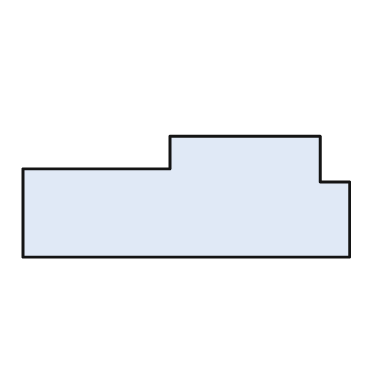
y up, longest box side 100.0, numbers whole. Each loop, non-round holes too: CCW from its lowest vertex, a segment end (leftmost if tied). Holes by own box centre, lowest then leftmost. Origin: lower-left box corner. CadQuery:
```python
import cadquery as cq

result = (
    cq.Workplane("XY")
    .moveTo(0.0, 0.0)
    .lineTo(100.0, 0.0)
    .lineTo(100.0, 23.0)
    .lineTo(91.0, 23.0)
    .lineTo(91.0, 37.0)
    .lineTo(45.0, 37.0)
    .lineTo(45.0, 27.0)
    .lineTo(0.0, 27.0)
    .close()
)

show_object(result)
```